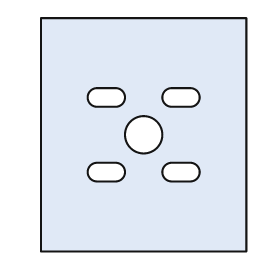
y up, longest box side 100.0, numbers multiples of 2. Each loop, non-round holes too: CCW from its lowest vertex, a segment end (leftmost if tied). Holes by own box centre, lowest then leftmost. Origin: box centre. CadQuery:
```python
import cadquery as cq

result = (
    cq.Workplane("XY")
    .moveTo(-44.0, -50.0)
    .lineTo(44.0, -50.0)
    .lineTo(44.0, 50.0)
    .lineTo(-44.0, 50.0)
    .close()
    .moveTo(-20.0, -20.0)
    .lineTo(-12.0, -20.0)
    .threePointArc((-8.0, -16.0), (-12.0, -12.0))
    .lineTo(-20.0, -12.0)
    .threePointArc((-24.0, -16.0), (-20.0, -20.0))
    .close()
    .moveTo(12.0, -20.0)
    .lineTo(20.0, -20.0)
    .threePointArc((24.0, -16.0), (20.0, -12.0))
    .lineTo(12.0, -12.0)
    .threePointArc((8.0, -16.0), (12.0, -20.0))
    .close()
    .moveTo(0.0, 0.0)
    .circle(8.0)
    .moveTo(-20.0, 12.0)
    .lineTo(-12.0, 12.0)
    .threePointArc((-8.0, 16.0), (-12.0, 20.0))
    .lineTo(-20.0, 20.0)
    .threePointArc((-24.0, 16.0), (-20.0, 12.0))
    .close()
    .moveTo(12.0, 12.0)
    .lineTo(20.0, 12.0)
    .threePointArc((24.0, 16.0), (20.0, 20.0))
    .lineTo(12.0, 20.0)
    .threePointArc((8.0, 16.0), (12.0, 12.0))
    .close()
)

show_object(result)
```